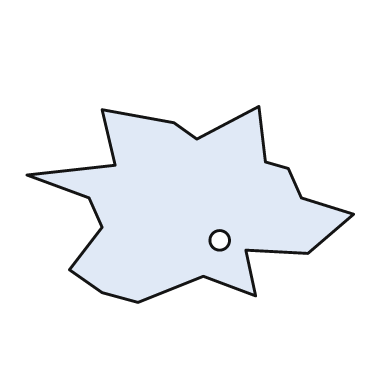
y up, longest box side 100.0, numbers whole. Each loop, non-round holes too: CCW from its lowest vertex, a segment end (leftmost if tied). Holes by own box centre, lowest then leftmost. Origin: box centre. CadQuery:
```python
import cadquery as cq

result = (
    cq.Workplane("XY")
    .moveTo(-16.0, -30.0)
    .lineTo(4.0, -22.0)
    .lineTo(20.0, -28.0)
    .lineTo(17.0, -14.0)
    .lineTo(36.0, -15.0)
    .lineTo(50.0, -3.0)
    .lineTo(34.0, 2.0)
    .lineTo(30.0, 11.0)
    .lineTo(23.0, 13.0)
    .lineTo(21.0, 30.0)
    .lineTo(2.0, 20.0)
    .lineTo(-5.0, 25.0)
    .lineTo(-27.0, 29.0)
    .lineTo(-23.0, 12.0)
    .lineTo(-50.0, 9.0)
    .lineTo(-31.0, 2.0)
    .lineTo(-27.0, -7.0)
    .lineTo(-37.0, -20.0)
    .lineTo(-27.0, -27.0)
    .close()
    .moveTo(9.0, -11.0)
    .circle(3.0)
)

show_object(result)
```